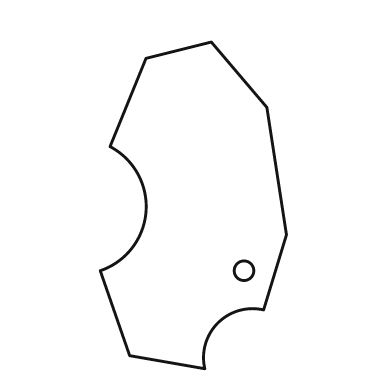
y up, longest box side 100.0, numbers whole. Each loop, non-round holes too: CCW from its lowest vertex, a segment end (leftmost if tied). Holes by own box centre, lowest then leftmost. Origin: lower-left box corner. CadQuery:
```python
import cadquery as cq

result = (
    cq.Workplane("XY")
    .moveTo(32.0, 0.0)
    .threePointArc((36.0, 14.0), (50.0, 18.0))
    .lineTo(57.0, 41.0)
    .lineTo(51.0, 80.0)
    .lineTo(34.0, 100.0)
    .lineTo(14.0, 95.0)
    .lineTo(3.0, 68.0)
    .threePointArc((14.0, 48.0), (0.0, 30.0))
    .lineTo(9.0, 4.0)
    .close()
    .moveTo(44.0, 30.0)
    .circle(3.0)
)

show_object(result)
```